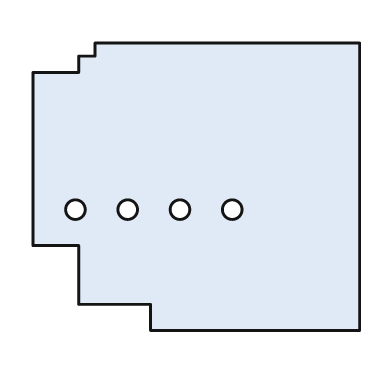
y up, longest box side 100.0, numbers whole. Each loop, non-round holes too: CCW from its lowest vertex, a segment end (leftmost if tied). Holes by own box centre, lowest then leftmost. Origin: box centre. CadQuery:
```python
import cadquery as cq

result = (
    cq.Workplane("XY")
    .moveTo(-14.0, -44.0)
    .lineTo(50.0, -44.0)
    .lineTo(50.0, 44.0)
    .lineTo(-31.0, 44.0)
    .lineTo(-31.0, 40.0)
    .lineTo(-36.0, 40.0)
    .lineTo(-36.0, 35.0)
    .lineTo(-50.0, 35.0)
    .lineTo(-50.0, -18.0)
    .lineTo(-36.0, -18.0)
    .lineTo(-36.0, -36.0)
    .lineTo(-14.0, -36.0)
    .close()
    .moveTo(-37.0, -7.0)
    .circle(3.0)
    .moveTo(-21.0, -7.0)
    .circle(3.0)
    .moveTo(-5.0, -7.0)
    .circle(3.0)
    .moveTo(11.0, -7.0)
    .circle(3.0)
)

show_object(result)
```